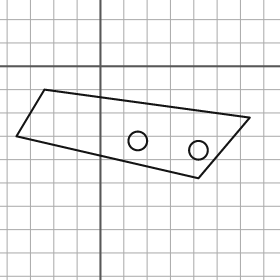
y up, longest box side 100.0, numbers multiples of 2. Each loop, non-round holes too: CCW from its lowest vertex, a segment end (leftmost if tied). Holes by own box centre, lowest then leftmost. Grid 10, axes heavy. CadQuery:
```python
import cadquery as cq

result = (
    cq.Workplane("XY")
    .moveTo(42.0, -48.0)
    .lineTo(64.0, -22.0)
    .lineTo(-24.0, -10.0)
    .lineTo(-36.0, -30.0)
    .close()
    .moveTo(42.0, -36.0)
    .circle(4.0)
    .moveTo(16.0, -32.0)
    .circle(4.0)
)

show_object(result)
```